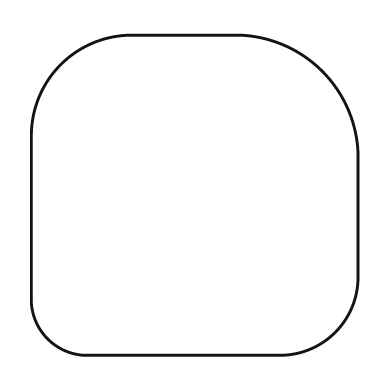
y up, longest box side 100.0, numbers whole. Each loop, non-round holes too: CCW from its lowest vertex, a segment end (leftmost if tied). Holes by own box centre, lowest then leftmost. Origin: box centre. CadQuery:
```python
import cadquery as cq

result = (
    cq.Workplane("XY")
    .moveTo(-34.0, -49.0)
    .lineTo(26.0, -49.0)
    .threePointArc((43.0, -42.0), (50.0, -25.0))
    .lineTo(50.0, 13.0)
    .threePointArc((39.0, 38.0), (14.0, 49.0))
    .lineTo(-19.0, 49.0)
    .threePointArc((-41.0, 40.0), (-50.0, 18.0))
    .lineTo(-50.0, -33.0)
    .threePointArc((-45.0, -44.0), (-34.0, -49.0))
    .close()
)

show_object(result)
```